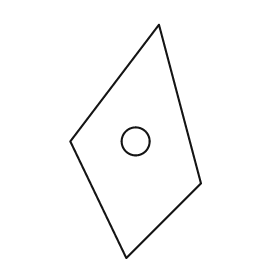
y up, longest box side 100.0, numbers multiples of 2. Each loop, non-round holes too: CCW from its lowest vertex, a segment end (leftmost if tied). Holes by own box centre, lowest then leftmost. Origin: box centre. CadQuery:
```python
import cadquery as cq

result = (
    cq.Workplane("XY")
    .moveTo(-4.0, -50.0)
    .lineTo(28.0, -18.0)
    .lineTo(10.0, 50.0)
    .lineTo(-28.0, 0.0)
    .close()
    .moveTo(0.0, 0.0)
    .circle(6.0)
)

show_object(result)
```